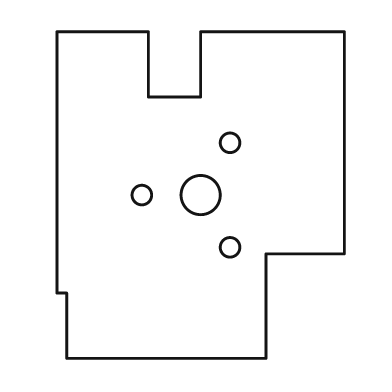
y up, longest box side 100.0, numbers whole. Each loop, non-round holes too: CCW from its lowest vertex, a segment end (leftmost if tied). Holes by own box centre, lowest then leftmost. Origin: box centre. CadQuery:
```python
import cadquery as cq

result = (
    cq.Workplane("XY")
    .moveTo(-41.0, -50.0)
    .lineTo(20.0, -50.0)
    .lineTo(20.0, -18.0)
    .lineTo(44.0, -18.0)
    .lineTo(44.0, 50.0)
    .lineTo(0.0, 50.0)
    .lineTo(0.0, 30.0)
    .lineTo(-16.0, 30.0)
    .lineTo(-16.0, 50.0)
    .lineTo(-44.0, 50.0)
    .lineTo(-44.0, -30.0)
    .lineTo(-41.0, -30.0)
    .close()
    .moveTo(9.0, -16.0)
    .circle(3.0)
    .moveTo(-18.0, 0.0)
    .circle(3.0)
    .moveTo(0.0, 0.0)
    .circle(6.0)
    .moveTo(9.0, 16.0)
    .circle(3.0)
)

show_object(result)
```